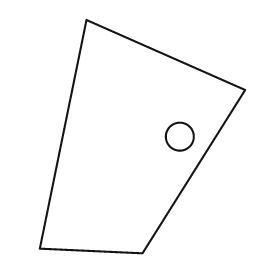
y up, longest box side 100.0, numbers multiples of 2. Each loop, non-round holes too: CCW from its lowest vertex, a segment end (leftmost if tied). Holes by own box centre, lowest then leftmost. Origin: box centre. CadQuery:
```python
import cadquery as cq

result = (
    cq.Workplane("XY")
    .moveTo(0.0, -50.0)
    .lineTo(44.0, 20.0)
    .lineTo(-24.0, 50.0)
    .lineTo(-44.0, -48.0)
    .close()
    .moveTo(16.0, 0.0)
    .circle(6.0)
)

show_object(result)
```